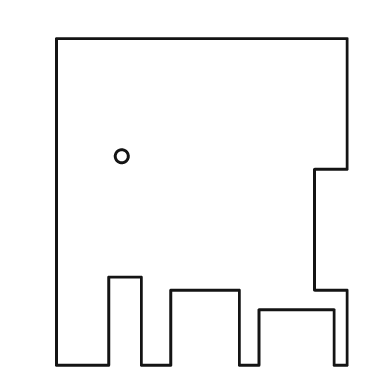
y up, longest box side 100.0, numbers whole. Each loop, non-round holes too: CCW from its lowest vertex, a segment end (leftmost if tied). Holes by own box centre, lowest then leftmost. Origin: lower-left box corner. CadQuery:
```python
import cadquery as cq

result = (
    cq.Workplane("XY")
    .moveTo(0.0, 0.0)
    .lineTo(16.0, 0.0)
    .lineTo(16.0, 27.0)
    .lineTo(26.0, 27.0)
    .lineTo(26.0, 0.0)
    .lineTo(35.0, 0.0)
    .lineTo(35.0, 23.0)
    .lineTo(56.0, 23.0)
    .lineTo(56.0, 0.0)
    .lineTo(62.0, 0.0)
    .lineTo(62.0, 17.0)
    .lineTo(85.0, 17.0)
    .lineTo(85.0, 0.0)
    .lineTo(89.0, 0.0)
    .lineTo(89.0, 23.0)
    .lineTo(79.0, 23.0)
    .lineTo(79.0, 60.0)
    .lineTo(89.0, 60.0)
    .lineTo(89.0, 100.0)
    .lineTo(0.0, 100.0)
    .close()
    .moveTo(20.0, 64.0)
    .circle(2.0)
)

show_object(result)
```